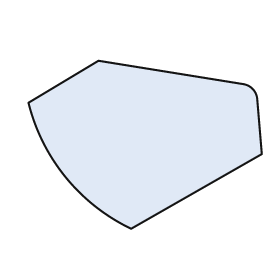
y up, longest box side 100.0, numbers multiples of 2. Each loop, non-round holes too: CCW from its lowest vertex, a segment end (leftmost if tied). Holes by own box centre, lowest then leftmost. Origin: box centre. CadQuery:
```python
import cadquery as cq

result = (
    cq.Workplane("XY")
    .moveTo(-6.0, -36.0)
    .lineTo(50.0, -4.0)
    .lineTo(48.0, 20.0)
    .threePointArc((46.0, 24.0), (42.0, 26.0))
    .lineTo(-20.0, 36.0)
    .lineTo(-50.0, 18.0)
    .threePointArc((-34.0, -14.0), (-6.0, -36.0))
    .close()
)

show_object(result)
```